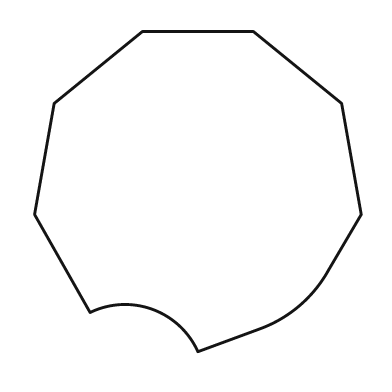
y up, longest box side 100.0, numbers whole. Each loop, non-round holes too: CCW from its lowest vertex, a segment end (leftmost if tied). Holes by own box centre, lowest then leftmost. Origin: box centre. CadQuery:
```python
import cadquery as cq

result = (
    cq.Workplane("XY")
    .moveTo(0.0, -49.0)
    .lineTo(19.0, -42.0)
    .threePointArc((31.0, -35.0), (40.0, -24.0))
    .lineTo(50.0, -7.0)
    .lineTo(44.0, 27.0)
    .lineTo(17.0, 49.0)
    .lineTo(-17.0, 49.0)
    .lineTo(-44.0, 27.0)
    .lineTo(-50.0, -7.0)
    .lineTo(-33.0, -37.0)
    .threePointArc((-14.0, -36.0), (0.0, -49.0))
    .close()
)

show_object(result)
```